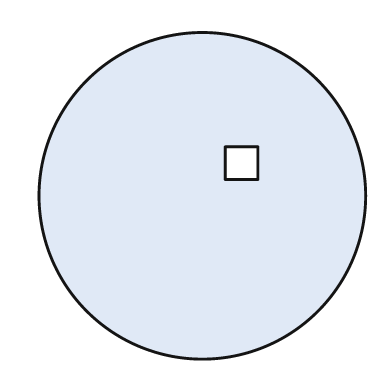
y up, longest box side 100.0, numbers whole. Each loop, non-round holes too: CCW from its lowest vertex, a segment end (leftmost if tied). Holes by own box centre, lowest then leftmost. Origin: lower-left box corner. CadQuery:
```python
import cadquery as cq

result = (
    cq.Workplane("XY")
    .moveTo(50.0, 50.0)
    .circle(50.0)
    .moveTo(57.0, 55.0)
    .lineTo(67.0, 55.0)
    .lineTo(67.0, 65.0)
    .lineTo(57.0, 65.0)
    .close()
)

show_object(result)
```